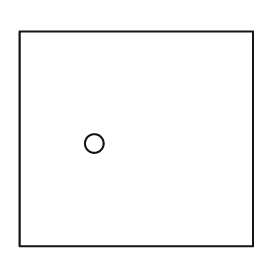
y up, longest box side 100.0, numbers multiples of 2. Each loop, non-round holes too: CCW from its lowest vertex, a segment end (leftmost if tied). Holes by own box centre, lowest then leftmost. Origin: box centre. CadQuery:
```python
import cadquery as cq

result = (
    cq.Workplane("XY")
    .moveTo(-50.0, -46.0)
    .lineTo(50.0, -46.0)
    .lineTo(50.0, 46.0)
    .lineTo(-50.0, 46.0)
    .close()
    .moveTo(-18.0, -2.0)
    .circle(4.0)
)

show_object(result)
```